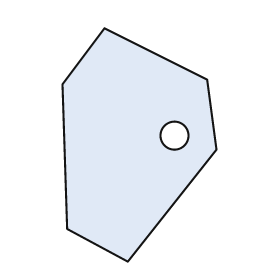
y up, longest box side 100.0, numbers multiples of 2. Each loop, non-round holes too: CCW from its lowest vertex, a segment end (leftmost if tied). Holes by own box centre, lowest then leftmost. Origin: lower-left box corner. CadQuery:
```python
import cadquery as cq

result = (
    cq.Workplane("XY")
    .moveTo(28.0, 0.0)
    .lineTo(66.0, 48.0)
    .lineTo(62.0, 78.0)
    .lineTo(18.0, 100.0)
    .lineTo(0.0, 76.0)
    .lineTo(2.0, 14.0)
    .close()
    .moveTo(48.0, 54.0)
    .circle(6.0)
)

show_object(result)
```